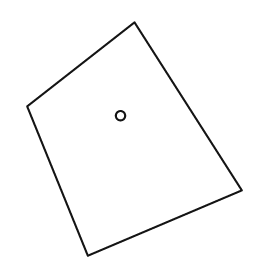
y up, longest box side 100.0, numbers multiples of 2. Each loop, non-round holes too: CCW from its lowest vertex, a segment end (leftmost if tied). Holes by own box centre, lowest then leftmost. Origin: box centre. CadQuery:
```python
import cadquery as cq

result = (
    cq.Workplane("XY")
    .moveTo(-20.0, -50.0)
    .lineTo(46.0, -22.0)
    .lineTo(0.0, 50.0)
    .lineTo(-46.0, 14.0)
    .close()
    .moveTo(-6.0, 10.0)
    .circle(2.0)
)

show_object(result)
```